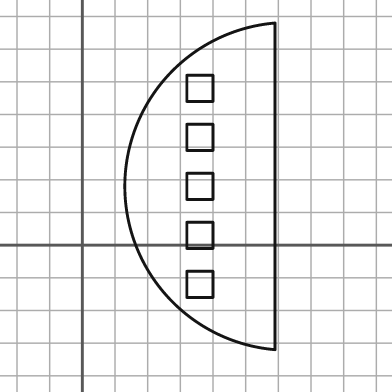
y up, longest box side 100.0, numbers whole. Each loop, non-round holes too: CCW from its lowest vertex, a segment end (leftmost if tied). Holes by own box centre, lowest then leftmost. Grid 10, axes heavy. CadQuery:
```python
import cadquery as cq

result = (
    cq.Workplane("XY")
    .moveTo(59.0, -32.0)
    .lineTo(59.0, 68.0)
    .threePointArc((13.0, 18.0), (59.0, -32.0))
    .close()
    .moveTo(32.0, -16.0)
    .lineTo(40.0, -16.0)
    .lineTo(40.0, -8.0)
    .lineTo(32.0, -8.0)
    .close()
    .moveTo(32.0, -1.0)
    .lineTo(40.0, -1.0)
    .lineTo(40.0, 7.0)
    .lineTo(32.0, 7.0)
    .close()
    .moveTo(32.0, 14.0)
    .lineTo(40.0, 14.0)
    .lineTo(40.0, 22.0)
    .lineTo(32.0, 22.0)
    .close()
    .moveTo(32.0, 29.0)
    .lineTo(40.0, 29.0)
    .lineTo(40.0, 37.0)
    .lineTo(32.0, 37.0)
    .close()
    .moveTo(32.0, 44.0)
    .lineTo(40.0, 44.0)
    .lineTo(40.0, 52.0)
    .lineTo(32.0, 52.0)
    .close()
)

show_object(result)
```